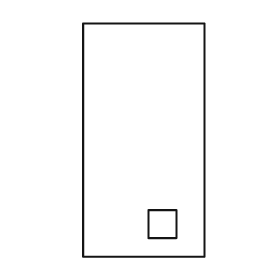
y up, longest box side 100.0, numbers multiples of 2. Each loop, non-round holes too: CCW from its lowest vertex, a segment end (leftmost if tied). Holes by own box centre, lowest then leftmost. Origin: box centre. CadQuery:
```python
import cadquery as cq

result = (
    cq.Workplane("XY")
    .moveTo(-26.0, -50.0)
    .lineTo(26.0, -50.0)
    .lineTo(26.0, 50.0)
    .lineTo(-26.0, 50.0)
    .close()
    .moveTo(2.0, -42.0)
    .lineTo(14.0, -42.0)
    .lineTo(14.0, -30.0)
    .lineTo(2.0, -30.0)
    .close()
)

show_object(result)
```